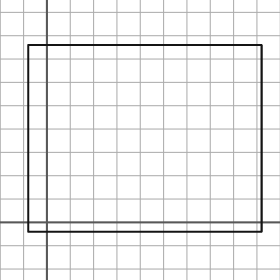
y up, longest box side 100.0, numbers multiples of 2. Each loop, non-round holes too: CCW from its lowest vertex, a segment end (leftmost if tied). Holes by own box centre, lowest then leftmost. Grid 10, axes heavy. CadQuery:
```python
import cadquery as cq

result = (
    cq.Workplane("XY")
    .moveTo(-8.0, -4.0)
    .lineTo(92.0, -4.0)
    .lineTo(92.0, 76.0)
    .lineTo(-8.0, 76.0)
    .close()
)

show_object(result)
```